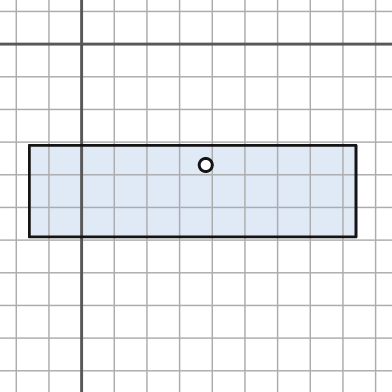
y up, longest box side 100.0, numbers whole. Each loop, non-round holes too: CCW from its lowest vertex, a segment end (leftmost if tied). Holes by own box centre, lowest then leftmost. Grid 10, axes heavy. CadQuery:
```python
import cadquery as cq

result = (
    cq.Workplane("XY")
    .moveTo(-16.0, -59.0)
    .lineTo(84.0, -59.0)
    .lineTo(84.0, -31.0)
    .lineTo(-16.0, -31.0)
    .close()
    .moveTo(38.0, -37.0)
    .circle(2.0)
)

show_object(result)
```